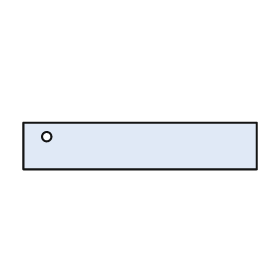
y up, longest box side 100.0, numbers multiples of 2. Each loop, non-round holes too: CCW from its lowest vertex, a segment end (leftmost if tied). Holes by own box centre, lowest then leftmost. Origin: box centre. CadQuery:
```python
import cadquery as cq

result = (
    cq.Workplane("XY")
    .moveTo(-50.0, -10.0)
    .lineTo(50.0, -10.0)
    .lineTo(50.0, 10.0)
    .lineTo(-50.0, 10.0)
    .close()
    .moveTo(-40.0, 4.0)
    .circle(2.0)
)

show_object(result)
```